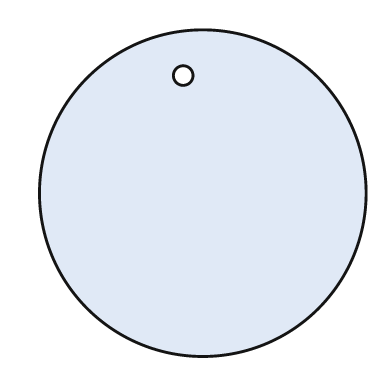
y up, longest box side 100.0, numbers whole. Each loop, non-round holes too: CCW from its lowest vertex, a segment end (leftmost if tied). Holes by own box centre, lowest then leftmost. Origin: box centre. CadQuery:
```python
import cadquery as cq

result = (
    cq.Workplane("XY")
    .moveTo(0.0, 0.0)
    .circle(50.0)
    .moveTo(-6.0, 36.0)
    .circle(3.0)
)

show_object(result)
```